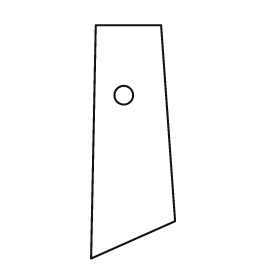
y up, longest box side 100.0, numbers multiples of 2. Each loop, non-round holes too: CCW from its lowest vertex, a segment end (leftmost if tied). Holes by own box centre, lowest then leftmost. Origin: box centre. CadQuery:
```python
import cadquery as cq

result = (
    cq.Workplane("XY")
    .moveTo(-18.0, -50.0)
    .lineTo(18.0, -34.0)
    .lineTo(12.0, 50.0)
    .lineTo(-16.0, 50.0)
    .close()
    .moveTo(-4.0, 20.0)
    .circle(4.0)
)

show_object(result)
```